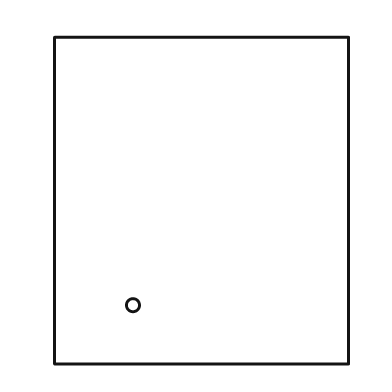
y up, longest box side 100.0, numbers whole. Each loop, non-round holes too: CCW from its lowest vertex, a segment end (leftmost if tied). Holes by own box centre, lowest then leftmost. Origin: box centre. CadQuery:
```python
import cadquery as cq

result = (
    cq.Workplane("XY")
    .moveTo(-45.0, -50.0)
    .lineTo(45.0, -50.0)
    .lineTo(45.0, 50.0)
    .lineTo(-45.0, 50.0)
    .close()
    .moveTo(-21.0, -32.0)
    .circle(2.0)
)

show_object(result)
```